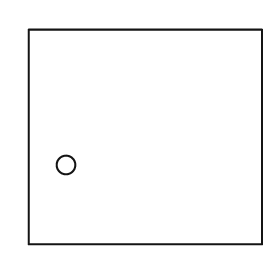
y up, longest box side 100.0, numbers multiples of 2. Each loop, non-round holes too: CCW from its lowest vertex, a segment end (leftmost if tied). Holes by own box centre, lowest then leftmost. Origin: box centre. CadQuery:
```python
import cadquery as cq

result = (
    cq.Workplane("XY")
    .moveTo(-50.0, -46.0)
    .lineTo(50.0, -46.0)
    .lineTo(50.0, 46.0)
    .lineTo(-50.0, 46.0)
    .close()
    .moveTo(-34.0, -12.0)
    .circle(4.0)
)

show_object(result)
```